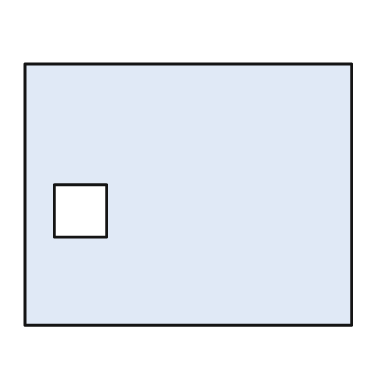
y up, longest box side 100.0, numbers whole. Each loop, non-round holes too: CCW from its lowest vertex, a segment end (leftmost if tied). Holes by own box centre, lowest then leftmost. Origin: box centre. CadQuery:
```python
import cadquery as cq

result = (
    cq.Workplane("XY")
    .moveTo(-50.0, -40.0)
    .lineTo(50.0, -40.0)
    .lineTo(50.0, 40.0)
    .lineTo(-50.0, 40.0)
    .close()
    .moveTo(-41.0, -13.0)
    .lineTo(-25.0, -13.0)
    .lineTo(-25.0, 3.0)
    .lineTo(-41.0, 3.0)
    .close()
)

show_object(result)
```